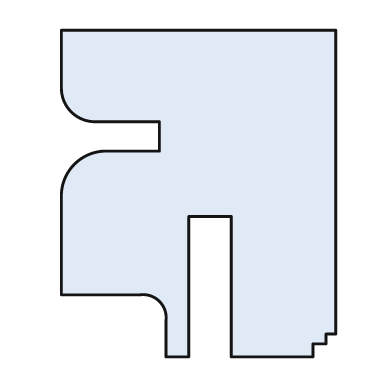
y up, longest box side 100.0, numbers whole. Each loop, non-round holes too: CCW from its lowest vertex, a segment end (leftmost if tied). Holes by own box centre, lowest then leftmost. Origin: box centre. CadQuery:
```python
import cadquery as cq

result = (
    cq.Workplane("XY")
    .moveTo(-10.0, -50.0)
    .lineTo(-3.0, -50.0)
    .lineTo(-3.0, -7.0)
    .lineTo(10.0, -7.0)
    .lineTo(10.0, -50.0)
    .lineTo(35.0, -50.0)
    .lineTo(35.0, -46.0)
    .lineTo(39.0, -46.0)
    .lineTo(39.0, -43.0)
    .lineTo(42.0, -43.0)
    .lineTo(42.0, 50.0)
    .lineTo(-42.0, 50.0)
    .lineTo(-42.0, 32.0)
    .threePointArc((-39.0, 25.0), (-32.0, 22.0))
    .lineTo(-12.0, 22.0)
    .lineTo(-12.0, 13.0)
    .lineTo(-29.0, 13.0)
    .threePointArc((-38.0, 9.0), (-42.0, 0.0))
    .lineTo(-42.0, -31.0)
    .lineTo(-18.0, -31.0)
    .threePointArc((-12.0, -33.0), (-10.0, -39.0))
    .close()
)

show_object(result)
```